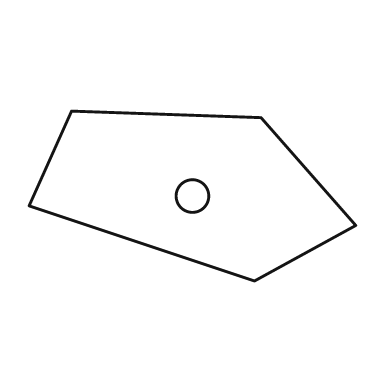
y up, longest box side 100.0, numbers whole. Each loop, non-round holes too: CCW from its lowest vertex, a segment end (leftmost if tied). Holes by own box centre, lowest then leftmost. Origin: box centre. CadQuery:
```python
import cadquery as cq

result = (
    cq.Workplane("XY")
    .moveTo(19.0, -26.0)
    .lineTo(50.0, -9.0)
    .lineTo(21.0, 24.0)
    .lineTo(-37.0, 26.0)
    .lineTo(-50.0, -3.0)
    .close()
    .moveTo(0.0, 0.0)
    .circle(5.0)
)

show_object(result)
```